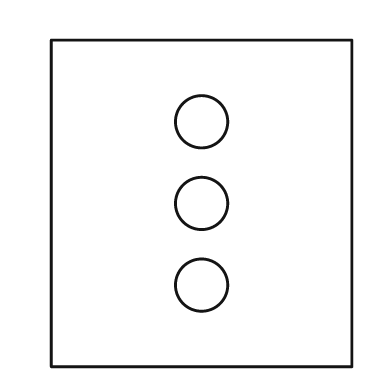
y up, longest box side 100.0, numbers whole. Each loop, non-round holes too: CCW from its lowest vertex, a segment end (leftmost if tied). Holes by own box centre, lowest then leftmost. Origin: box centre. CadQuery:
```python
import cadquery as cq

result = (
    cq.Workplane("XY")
    .moveTo(-46.0, -50.0)
    .lineTo(46.0, -50.0)
    .lineTo(46.0, 50.0)
    .lineTo(-46.0, 50.0)
    .close()
    .moveTo(0.0, -25.0)
    .circle(8.0)
    .moveTo(0.0, 0.0)
    .circle(8.0)
    .moveTo(0.0, 25.0)
    .circle(8.0)
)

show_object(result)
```